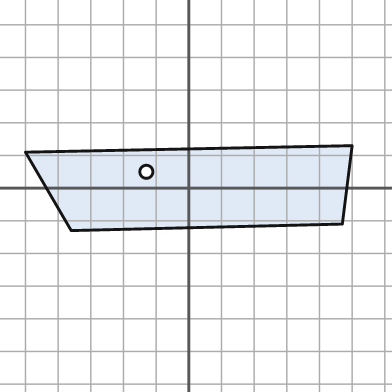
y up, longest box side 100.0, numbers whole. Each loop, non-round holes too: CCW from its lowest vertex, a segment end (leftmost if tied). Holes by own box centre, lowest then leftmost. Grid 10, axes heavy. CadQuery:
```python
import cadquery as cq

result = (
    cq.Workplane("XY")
    .moveTo(-36.0, -13.0)
    .lineTo(47.0, -11.0)
    .lineTo(50.0, 13.0)
    .lineTo(-50.0, 11.0)
    .close()
    .moveTo(-13.0, 5.0)
    .circle(2.0)
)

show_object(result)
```